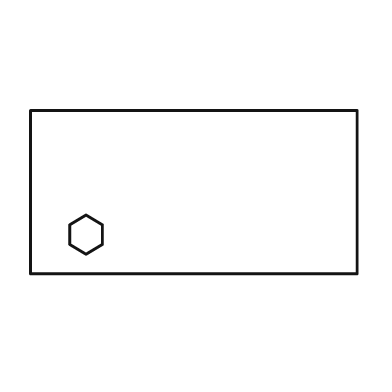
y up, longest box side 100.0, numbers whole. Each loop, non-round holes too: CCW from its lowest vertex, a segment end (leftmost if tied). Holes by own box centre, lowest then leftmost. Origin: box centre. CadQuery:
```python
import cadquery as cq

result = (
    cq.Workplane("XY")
    .moveTo(-50.0, -25.0)
    .lineTo(50.0, -25.0)
    .lineTo(50.0, 25.0)
    .lineTo(-50.0, 25.0)
    .close()
    .moveTo(-33.0, -19.0)
    .lineTo(-28.0, -16.0)
    .lineTo(-28.0, -10.0)
    .lineTo(-33.0, -7.0)
    .lineTo(-38.0, -10.0)
    .lineTo(-38.0, -16.0)
    .close()
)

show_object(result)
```